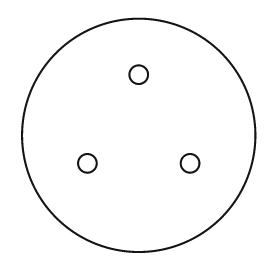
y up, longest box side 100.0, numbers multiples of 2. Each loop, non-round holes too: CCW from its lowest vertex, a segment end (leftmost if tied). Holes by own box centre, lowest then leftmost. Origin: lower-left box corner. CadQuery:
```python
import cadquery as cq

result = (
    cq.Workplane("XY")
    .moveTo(50.0, 50.0)
    .circle(50.0)
    .moveTo(28.0, 38.0)
    .circle(4.0)
    .moveTo(72.0, 38.0)
    .circle(4.0)
    .moveTo(50.0, 76.0)
    .circle(4.0)
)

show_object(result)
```